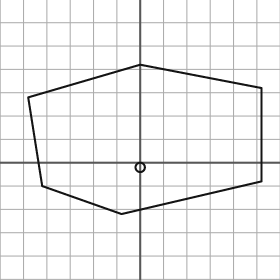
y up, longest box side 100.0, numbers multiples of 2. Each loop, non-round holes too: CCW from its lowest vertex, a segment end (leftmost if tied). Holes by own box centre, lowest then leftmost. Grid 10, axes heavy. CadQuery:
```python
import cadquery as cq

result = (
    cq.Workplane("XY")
    .moveTo(-8.0, -22.0)
    .lineTo(52.0, -8.0)
    .lineTo(52.0, 32.0)
    .lineTo(0.0, 42.0)
    .lineTo(-48.0, 28.0)
    .lineTo(-42.0, -10.0)
    .close()
    .moveTo(0.0, -2.0)
    .circle(2.0)
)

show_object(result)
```